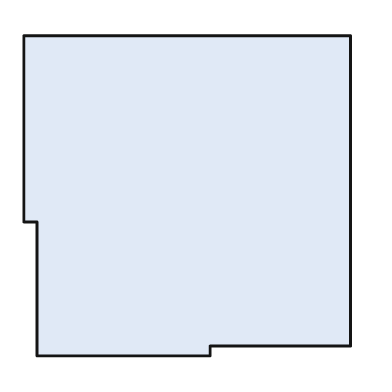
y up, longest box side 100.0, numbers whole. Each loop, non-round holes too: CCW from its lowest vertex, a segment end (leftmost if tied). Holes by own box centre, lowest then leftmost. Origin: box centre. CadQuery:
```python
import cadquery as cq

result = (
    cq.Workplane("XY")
    .moveTo(-46.0, -49.0)
    .lineTo(7.0, -49.0)
    .lineTo(7.0, -46.0)
    .lineTo(50.0, -46.0)
    .lineTo(50.0, 49.0)
    .lineTo(-50.0, 49.0)
    .lineTo(-50.0, -8.0)
    .lineTo(-46.0, -8.0)
    .close()
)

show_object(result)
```